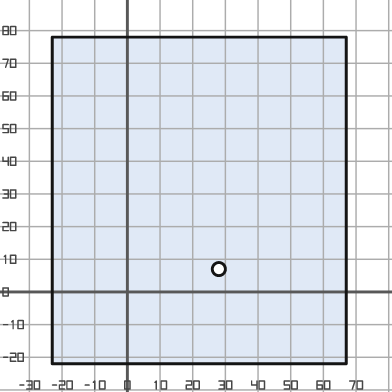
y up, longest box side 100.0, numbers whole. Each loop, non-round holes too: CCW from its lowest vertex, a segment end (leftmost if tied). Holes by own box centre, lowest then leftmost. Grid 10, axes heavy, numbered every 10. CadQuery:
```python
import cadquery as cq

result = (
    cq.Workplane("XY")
    .moveTo(-23.0, -22.0)
    .lineTo(67.0, -22.0)
    .lineTo(67.0, 78.0)
    .lineTo(-23.0, 78.0)
    .close()
    .moveTo(28.0, 7.0)
    .circle(2.0)
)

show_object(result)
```